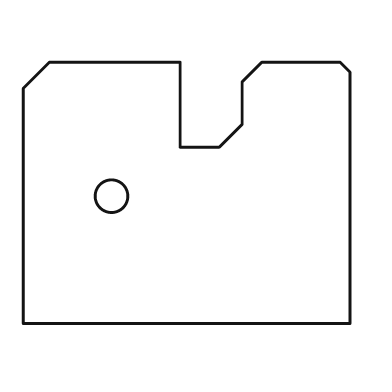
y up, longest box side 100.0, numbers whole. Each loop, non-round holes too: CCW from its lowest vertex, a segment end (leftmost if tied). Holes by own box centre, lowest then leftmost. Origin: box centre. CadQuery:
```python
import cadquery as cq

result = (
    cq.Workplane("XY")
    .moveTo(-50.0, -40.0)
    .lineTo(50.0, -40.0)
    .lineTo(50.0, 37.0)
    .lineTo(47.0, 40.0)
    .lineTo(23.0, 40.0)
    .lineTo(17.0, 34.0)
    .lineTo(17.0, 21.0)
    .lineTo(10.0, 14.0)
    .lineTo(-2.0, 14.0)
    .lineTo(-2.0, 40.0)
    .lineTo(-42.0, 40.0)
    .lineTo(-50.0, 32.0)
    .close()
    .moveTo(-23.0, -1.0)
    .circle(5.0)
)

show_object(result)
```